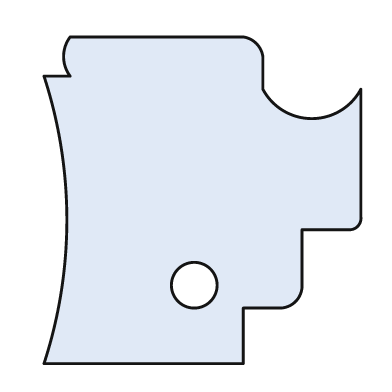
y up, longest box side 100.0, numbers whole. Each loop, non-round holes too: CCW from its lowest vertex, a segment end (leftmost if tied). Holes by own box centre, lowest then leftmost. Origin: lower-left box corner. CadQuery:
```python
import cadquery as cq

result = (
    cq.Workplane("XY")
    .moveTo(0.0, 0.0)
    .lineTo(61.0, 0.0)
    .lineTo(61.0, 17.0)
    .lineTo(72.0, 17.0)
    .threePointArc((77.0, 19.0), (79.0, 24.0))
    .lineTo(79.0, 41.0)
    .lineTo(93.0, 41.0)
    .threePointArc((96.0, 42.0), (97.0, 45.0))
    .lineTo(97.0, 84.0)
    .threePointArc((82.0, 75.0), (67.0, 84.0))
    .lineTo(67.0, 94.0)
    .threePointArc((65.0, 98.0), (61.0, 100.0))
    .lineTo(8.0, 100.0)
    .threePointArc((6.0, 94.0), (8.0, 88.0))
    .lineTo(0.0, 88.0)
    .threePointArc((7.0, 44.0), (0.0, 0.0))
    .close()
    .moveTo(46.0, 24.0)
    .circle(7.0)
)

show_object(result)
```